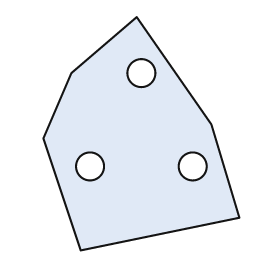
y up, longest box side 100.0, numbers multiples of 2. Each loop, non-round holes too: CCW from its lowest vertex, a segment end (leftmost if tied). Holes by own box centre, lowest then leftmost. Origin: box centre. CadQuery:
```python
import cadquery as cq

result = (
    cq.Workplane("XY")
    .moveTo(-26.0, -50.0)
    .lineTo(42.0, -36.0)
    .lineTo(30.0, 4.0)
    .lineTo(-2.0, 50.0)
    .lineTo(-30.0, 26.0)
    .lineTo(-42.0, -2.0)
    .close()
    .moveTo(-22.0, -14.0)
    .circle(6.0)
    .moveTo(22.0, -14.0)
    .circle(6.0)
    .moveTo(0.0, 26.0)
    .circle(6.0)
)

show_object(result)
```